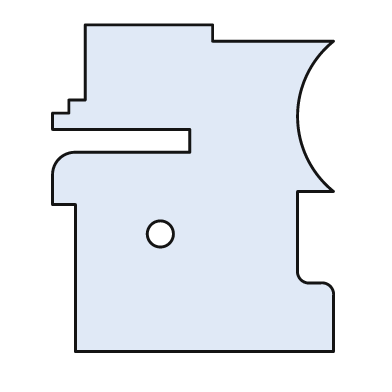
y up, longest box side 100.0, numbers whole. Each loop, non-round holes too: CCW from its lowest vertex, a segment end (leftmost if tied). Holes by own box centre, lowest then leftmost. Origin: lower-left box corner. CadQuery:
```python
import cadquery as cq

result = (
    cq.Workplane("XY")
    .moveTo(7.0, 0.0)
    .lineTo(86.0, 0.0)
    .lineTo(86.0, 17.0)
    .threePointArc((85.0, 20.0), (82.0, 21.0))
    .lineTo(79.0, 21.0)
    .threePointArc((76.0, 22.0), (75.0, 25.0))
    .lineTo(75.0, 49.0)
    .lineTo(86.0, 49.0)
    .threePointArc((75.0, 72.0), (86.0, 95.0))
    .lineTo(49.0, 95.0)
    .lineTo(49.0, 100.0)
    .lineTo(10.0, 100.0)
    .lineTo(10.0, 77.0)
    .lineTo(5.0, 77.0)
    .lineTo(5.0, 73.0)
    .lineTo(0.0, 73.0)
    .lineTo(0.0, 68.0)
    .lineTo(42.0, 68.0)
    .lineTo(42.0, 61.0)
    .lineTo(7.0, 61.0)
    .threePointArc((2.0, 59.0), (0.0, 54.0))
    .lineTo(0.0, 45.0)
    .lineTo(7.0, 45.0)
    .close()
    .moveTo(33.0, 36.0)
    .circle(4.0)
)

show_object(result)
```